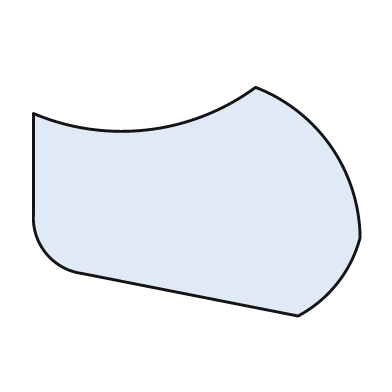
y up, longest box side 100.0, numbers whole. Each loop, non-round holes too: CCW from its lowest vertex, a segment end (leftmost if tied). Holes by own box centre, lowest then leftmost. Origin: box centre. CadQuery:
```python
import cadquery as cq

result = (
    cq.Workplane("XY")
    .moveTo(31.0, -35.0)
    .threePointArc((43.0, -25.0), (50.0, -11.0))
    .threePointArc((41.0, 17.0), (18.0, 35.0))
    .threePointArc((-15.0, 22.0), (-50.0, 27.0))
    .lineTo(-50.0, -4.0)
    .threePointArc((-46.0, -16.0), (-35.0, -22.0))
    .close()
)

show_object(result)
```